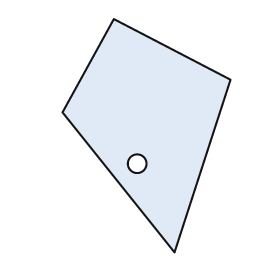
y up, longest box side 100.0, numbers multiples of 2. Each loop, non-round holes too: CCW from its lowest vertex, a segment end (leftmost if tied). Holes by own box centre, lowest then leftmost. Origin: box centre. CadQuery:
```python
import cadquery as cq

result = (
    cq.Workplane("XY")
    .moveTo(12.0, -50.0)
    .lineTo(36.0, 24.0)
    .lineTo(-14.0, 50.0)
    .lineTo(-36.0, 10.0)
    .close()
    .moveTo(-4.0, -12.0)
    .circle(4.0)
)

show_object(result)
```